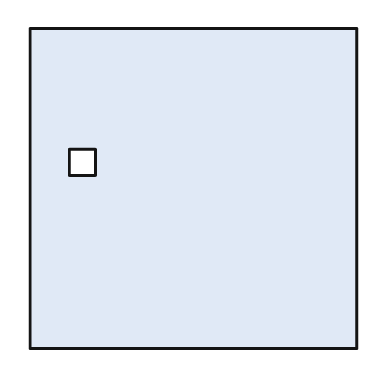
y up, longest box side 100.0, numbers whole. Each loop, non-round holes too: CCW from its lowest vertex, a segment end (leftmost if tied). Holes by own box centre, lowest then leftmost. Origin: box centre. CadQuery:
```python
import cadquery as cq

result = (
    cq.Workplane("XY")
    .moveTo(-50.0, -49.0)
    .lineTo(50.0, -49.0)
    .lineTo(50.0, 49.0)
    .lineTo(-50.0, 49.0)
    .close()
    .moveTo(-38.0, 4.0)
    .lineTo(-30.0, 4.0)
    .lineTo(-30.0, 12.0)
    .lineTo(-38.0, 12.0)
    .close()
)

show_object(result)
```